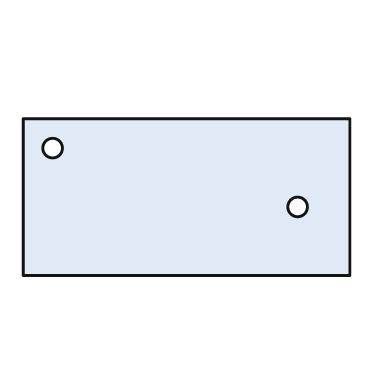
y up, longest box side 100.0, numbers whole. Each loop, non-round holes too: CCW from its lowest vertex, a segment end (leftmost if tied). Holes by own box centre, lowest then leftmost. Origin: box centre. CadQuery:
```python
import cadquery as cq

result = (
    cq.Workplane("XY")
    .moveTo(-50.0, -24.0)
    .lineTo(50.0, -24.0)
    .lineTo(50.0, 24.0)
    .lineTo(-50.0, 24.0)
    .close()
    .moveTo(34.0, -3.0)
    .circle(3.0)
    .moveTo(-41.0, 15.0)
    .circle(3.0)
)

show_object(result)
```